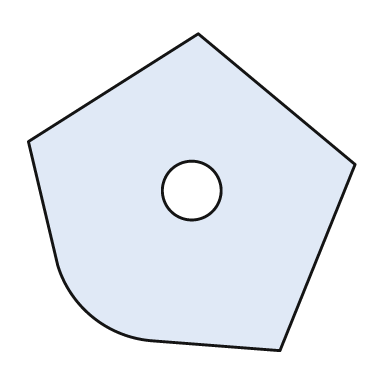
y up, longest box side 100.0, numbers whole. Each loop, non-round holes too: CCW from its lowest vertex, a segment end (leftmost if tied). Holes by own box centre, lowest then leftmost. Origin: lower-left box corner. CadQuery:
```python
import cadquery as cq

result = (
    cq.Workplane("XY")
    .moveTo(77.0, 0.0)
    .lineTo(100.0, 57.0)
    .lineTo(52.0, 97.0)
    .lineTo(0.0, 64.0)
    .lineTo(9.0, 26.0)
    .threePointArc((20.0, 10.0), (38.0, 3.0))
    .close()
    .moveTo(50.0, 49.0)
    .circle(9.0)
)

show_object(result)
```